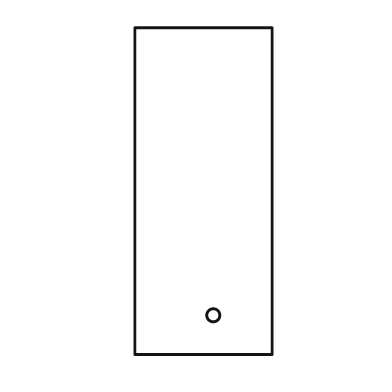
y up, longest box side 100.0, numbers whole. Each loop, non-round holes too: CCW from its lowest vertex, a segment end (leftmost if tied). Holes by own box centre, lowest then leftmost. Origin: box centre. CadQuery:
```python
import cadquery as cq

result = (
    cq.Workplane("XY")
    .moveTo(-21.0, -50.0)
    .lineTo(21.0, -50.0)
    .lineTo(21.0, 50.0)
    .lineTo(-21.0, 50.0)
    .close()
    .moveTo(3.0, -38.0)
    .circle(2.0)
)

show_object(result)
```